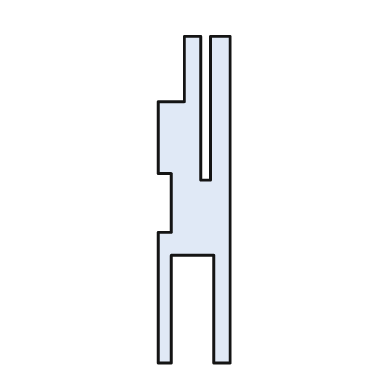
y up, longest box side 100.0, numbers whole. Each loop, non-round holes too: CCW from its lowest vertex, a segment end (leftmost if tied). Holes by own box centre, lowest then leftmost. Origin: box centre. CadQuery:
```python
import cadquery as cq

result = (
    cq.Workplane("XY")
    .moveTo(-11.0, -50.0)
    .lineTo(-7.0, -50.0)
    .lineTo(-7.0, -17.0)
    .lineTo(6.0, -17.0)
    .lineTo(6.0, -50.0)
    .lineTo(11.0, -50.0)
    .lineTo(11.0, 50.0)
    .lineTo(5.0, 50.0)
    .lineTo(5.0, 6.0)
    .lineTo(2.0, 6.0)
    .lineTo(2.0, 50.0)
    .lineTo(-3.0, 50.0)
    .lineTo(-3.0, 30.0)
    .lineTo(-11.0, 30.0)
    .lineTo(-11.0, 8.0)
    .lineTo(-7.0, 8.0)
    .lineTo(-7.0, -10.0)
    .lineTo(-11.0, -10.0)
    .close()
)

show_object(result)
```